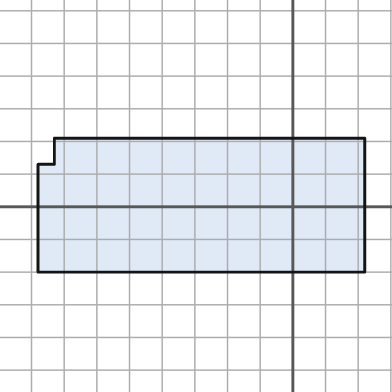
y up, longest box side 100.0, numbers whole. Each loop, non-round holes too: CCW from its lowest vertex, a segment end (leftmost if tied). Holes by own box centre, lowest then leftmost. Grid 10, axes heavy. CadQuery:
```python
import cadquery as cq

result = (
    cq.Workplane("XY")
    .moveTo(-78.0, -20.0)
    .lineTo(22.0, -20.0)
    .lineTo(22.0, 21.0)
    .lineTo(-73.0, 21.0)
    .lineTo(-73.0, 13.0)
    .lineTo(-78.0, 13.0)
    .close()
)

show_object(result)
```